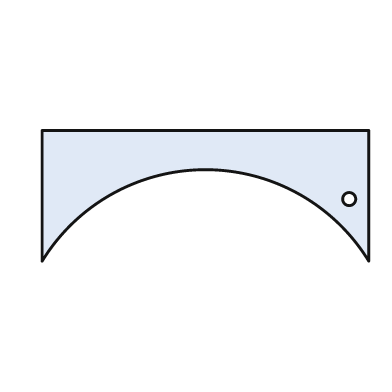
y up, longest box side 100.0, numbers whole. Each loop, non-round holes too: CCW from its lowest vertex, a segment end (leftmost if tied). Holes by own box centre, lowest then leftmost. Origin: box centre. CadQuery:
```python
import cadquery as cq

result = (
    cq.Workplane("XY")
    .moveTo(-50.0, -20.0)
    .threePointArc((0.0, 8.0), (50.0, -20.0))
    .lineTo(50.0, 20.0)
    .lineTo(-50.0, 20.0)
    .close()
    .moveTo(44.0, -1.0)
    .circle(2.0)
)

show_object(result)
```